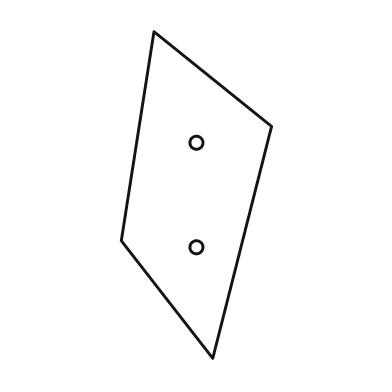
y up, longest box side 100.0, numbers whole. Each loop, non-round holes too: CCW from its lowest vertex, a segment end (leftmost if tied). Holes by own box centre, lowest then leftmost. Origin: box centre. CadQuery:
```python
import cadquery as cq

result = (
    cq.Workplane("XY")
    .moveTo(5.0, -50.0)
    .lineTo(23.0, 21.0)
    .lineTo(-13.0, 50.0)
    .lineTo(-23.0, -14.0)
    .close()
    .moveTo(0.0, -16.0)
    .circle(2.0)
    .moveTo(0.0, 16.0)
    .circle(2.0)
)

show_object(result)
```